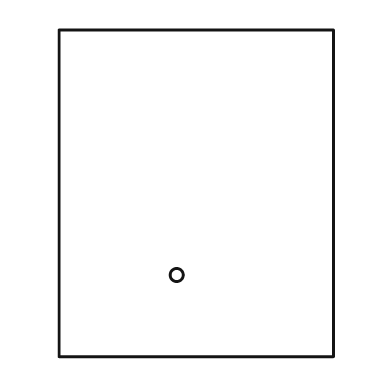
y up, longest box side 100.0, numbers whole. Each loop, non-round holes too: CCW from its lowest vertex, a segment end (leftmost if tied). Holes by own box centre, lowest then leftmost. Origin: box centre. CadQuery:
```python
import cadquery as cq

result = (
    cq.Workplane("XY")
    .moveTo(-42.0, -50.0)
    .lineTo(42.0, -50.0)
    .lineTo(42.0, 50.0)
    .lineTo(-42.0, 50.0)
    .close()
    .moveTo(-6.0, -25.0)
    .circle(2.0)
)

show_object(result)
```